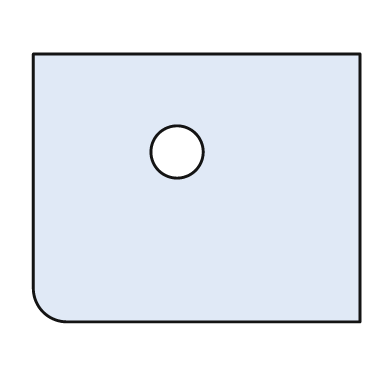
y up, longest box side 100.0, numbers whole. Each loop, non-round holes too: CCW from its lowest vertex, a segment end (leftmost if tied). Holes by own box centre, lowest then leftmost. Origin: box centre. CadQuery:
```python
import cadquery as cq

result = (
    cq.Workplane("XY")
    .moveTo(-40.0, -41.0)
    .lineTo(50.0, -41.0)
    .lineTo(50.0, 41.0)
    .lineTo(-50.0, 41.0)
    .lineTo(-50.0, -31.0)
    .threePointArc((-47.0, -38.0), (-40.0, -41.0))
    .close()
    .moveTo(-6.0, 11.0)
    .circle(8.0)
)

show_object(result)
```